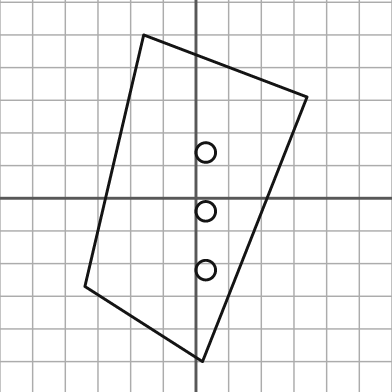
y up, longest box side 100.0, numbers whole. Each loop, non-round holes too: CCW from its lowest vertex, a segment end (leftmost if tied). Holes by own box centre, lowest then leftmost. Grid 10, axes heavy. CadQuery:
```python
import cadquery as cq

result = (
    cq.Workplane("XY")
    .moveTo(2.0, -50.0)
    .lineTo(34.0, 31.0)
    .lineTo(-16.0, 50.0)
    .lineTo(-34.0, -27.0)
    .close()
    .moveTo(3.0, -22.0)
    .circle(3.0)
    .moveTo(3.0, -4.0)
    .circle(3.0)
    .moveTo(3.0, 14.0)
    .circle(3.0)
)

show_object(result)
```